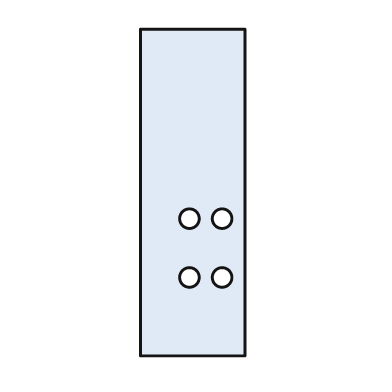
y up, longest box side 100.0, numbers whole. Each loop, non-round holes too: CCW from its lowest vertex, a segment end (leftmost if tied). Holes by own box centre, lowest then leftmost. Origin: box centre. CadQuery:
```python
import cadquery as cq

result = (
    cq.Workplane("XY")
    .moveTo(-16.0, -50.0)
    .lineTo(16.0, -50.0)
    .lineTo(16.0, 50.0)
    .lineTo(-16.0, 50.0)
    .close()
    .moveTo(-1.0, -26.0)
    .circle(3.0)
    .moveTo(9.0, -26.0)
    .circle(3.0)
    .moveTo(-1.0, -8.0)
    .circle(3.0)
    .moveTo(9.0, -8.0)
    .circle(3.0)
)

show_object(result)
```